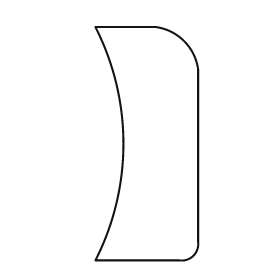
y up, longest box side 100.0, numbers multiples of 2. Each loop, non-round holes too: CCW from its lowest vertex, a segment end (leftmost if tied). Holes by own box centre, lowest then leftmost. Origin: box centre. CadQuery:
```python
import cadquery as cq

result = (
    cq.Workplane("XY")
    .moveTo(-22.0, -50.0)
    .lineTo(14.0, -50.0)
    .threePointArc((20.0, -48.0), (22.0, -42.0))
    .lineTo(22.0, 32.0)
    .threePointArc((16.0, 44.0), (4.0, 50.0))
    .lineTo(-22.0, 50.0)
    .threePointArc((-10.0, 0.0), (-22.0, -50.0))
    .close()
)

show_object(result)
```